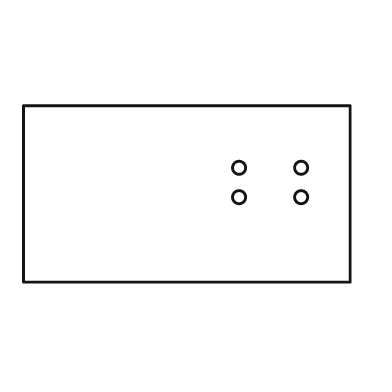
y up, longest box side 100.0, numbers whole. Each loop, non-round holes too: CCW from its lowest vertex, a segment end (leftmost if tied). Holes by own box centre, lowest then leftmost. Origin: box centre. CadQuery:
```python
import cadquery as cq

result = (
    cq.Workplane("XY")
    .moveTo(-50.0, -27.0)
    .lineTo(50.0, -27.0)
    .lineTo(50.0, 27.0)
    .lineTo(-50.0, 27.0)
    .close()
    .moveTo(16.0, -1.0)
    .circle(2.0)
    .moveTo(35.0, -1.0)
    .circle(2.0)
    .moveTo(16.0, 8.0)
    .circle(2.0)
    .moveTo(35.0, 8.0)
    .circle(2.0)
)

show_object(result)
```